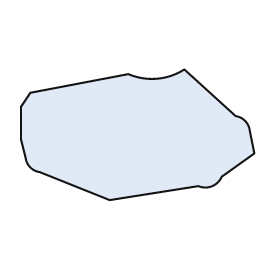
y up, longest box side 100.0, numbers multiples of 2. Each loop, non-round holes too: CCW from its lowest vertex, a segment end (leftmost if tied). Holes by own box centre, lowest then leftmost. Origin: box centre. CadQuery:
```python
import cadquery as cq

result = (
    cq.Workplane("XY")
    .moveTo(-12.0, -28.0)
    .lineTo(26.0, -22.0)
    .threePointArc((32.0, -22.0), (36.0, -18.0))
    .lineTo(50.0, -8.0)
    .lineTo(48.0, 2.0)
    .threePointArc((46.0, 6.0), (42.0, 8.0))
    .lineTo(20.0, 28.0)
    .threePointArc((8.0, 24.0), (-4.0, 26.0))
    .lineTo(-46.0, 18.0)
    .lineTo(-50.0, 12.0)
    .lineTo(-50.0, -2.0)
    .lineTo(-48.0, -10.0)
    .threePointArc((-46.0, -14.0), (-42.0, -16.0))
    .close()
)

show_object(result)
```